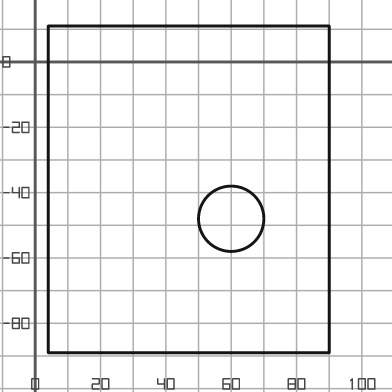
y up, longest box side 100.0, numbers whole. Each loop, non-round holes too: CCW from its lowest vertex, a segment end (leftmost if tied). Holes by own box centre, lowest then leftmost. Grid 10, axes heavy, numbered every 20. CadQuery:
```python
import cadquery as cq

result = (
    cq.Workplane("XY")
    .moveTo(4.0, -89.0)
    .lineTo(90.0, -89.0)
    .lineTo(90.0, 11.0)
    .lineTo(4.0, 11.0)
    .close()
    .moveTo(60.0, -48.0)
    .circle(10.0)
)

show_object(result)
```